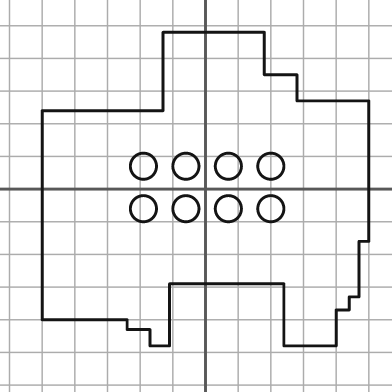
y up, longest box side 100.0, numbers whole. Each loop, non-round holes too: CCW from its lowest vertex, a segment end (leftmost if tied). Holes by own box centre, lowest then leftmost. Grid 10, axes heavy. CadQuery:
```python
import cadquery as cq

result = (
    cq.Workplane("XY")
    .moveTo(-17.0, -48.0)
    .lineTo(-11.0, -48.0)
    .lineTo(-11.0, -29.0)
    .lineTo(24.0, -29.0)
    .lineTo(24.0, -48.0)
    .lineTo(40.0, -48.0)
    .lineTo(40.0, -37.0)
    .lineTo(44.0, -37.0)
    .lineTo(44.0, -33.0)
    .lineTo(47.0, -33.0)
    .lineTo(47.0, -16.0)
    .lineTo(50.0, -16.0)
    .lineTo(50.0, 27.0)
    .lineTo(28.0, 27.0)
    .lineTo(28.0, 35.0)
    .lineTo(18.0, 35.0)
    .lineTo(18.0, 48.0)
    .lineTo(-13.0, 48.0)
    .lineTo(-13.0, 24.0)
    .lineTo(-50.0, 24.0)
    .lineTo(-50.0, -40.0)
    .lineTo(-24.0, -40.0)
    .lineTo(-24.0, -43.0)
    .lineTo(-17.0, -43.0)
    .close()
    .moveTo(-19.0, -6.0)
    .circle(4.0)
    .moveTo(-6.0, -6.0)
    .circle(4.0)
    .moveTo(7.0, -6.0)
    .circle(4.0)
    .moveTo(20.0, -6.0)
    .circle(4.0)
    .moveTo(-19.0, 7.0)
    .circle(4.0)
    .moveTo(-6.0, 7.0)
    .circle(4.0)
    .moveTo(7.0, 7.0)
    .circle(4.0)
    .moveTo(20.0, 7.0)
    .circle(4.0)
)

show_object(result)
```